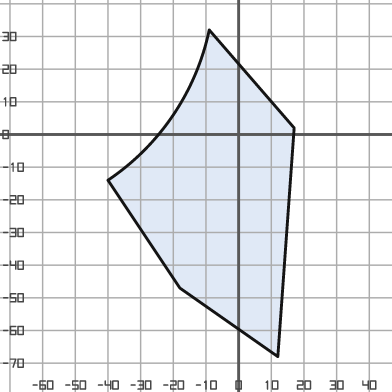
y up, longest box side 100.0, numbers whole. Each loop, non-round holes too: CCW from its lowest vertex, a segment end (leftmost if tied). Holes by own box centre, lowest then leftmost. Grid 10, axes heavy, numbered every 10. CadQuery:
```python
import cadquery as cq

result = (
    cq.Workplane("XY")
    .moveTo(12.0, -68.0)
    .lineTo(17.0, 2.0)
    .lineTo(-9.0, 32.0)
    .threePointArc((-20.0, 6.0), (-40.0, -14.0))
    .lineTo(-18.0, -47.0)
    .close()
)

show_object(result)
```